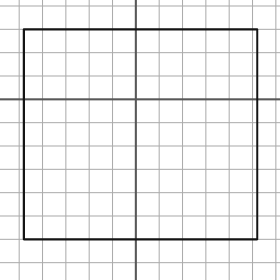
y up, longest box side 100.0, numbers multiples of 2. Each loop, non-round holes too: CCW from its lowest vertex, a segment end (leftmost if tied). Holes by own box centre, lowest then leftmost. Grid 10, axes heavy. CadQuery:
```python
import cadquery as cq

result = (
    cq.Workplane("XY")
    .moveTo(-48.0, -60.0)
    .lineTo(52.0, -60.0)
    .lineTo(52.0, 30.0)
    .lineTo(-48.0, 30.0)
    .close()
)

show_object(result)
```